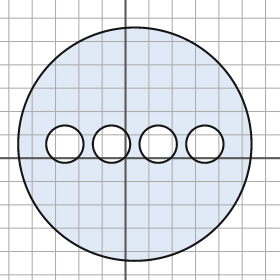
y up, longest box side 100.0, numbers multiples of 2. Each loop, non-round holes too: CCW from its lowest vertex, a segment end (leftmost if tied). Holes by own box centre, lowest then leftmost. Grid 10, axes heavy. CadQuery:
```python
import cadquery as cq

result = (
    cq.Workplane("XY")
    .moveTo(4.0, 6.0)
    .circle(50.0)
    .moveTo(-26.0, 6.0)
    .circle(8.0)
    .moveTo(-6.0, 6.0)
    .circle(8.0)
    .moveTo(14.0, 6.0)
    .circle(8.0)
    .moveTo(34.0, 6.0)
    .circle(8.0)
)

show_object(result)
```